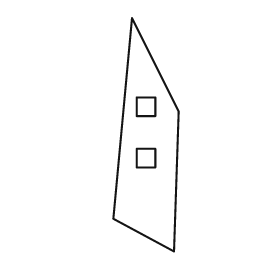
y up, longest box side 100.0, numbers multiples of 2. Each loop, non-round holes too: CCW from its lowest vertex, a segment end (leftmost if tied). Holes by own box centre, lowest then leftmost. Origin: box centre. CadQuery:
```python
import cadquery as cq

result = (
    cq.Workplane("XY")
    .moveTo(12.0, -50.0)
    .lineTo(14.0, 10.0)
    .lineTo(-6.0, 50.0)
    .lineTo(-14.0, -36.0)
    .close()
    .moveTo(-4.0, -14.0)
    .lineTo(4.0, -14.0)
    .lineTo(4.0, -6.0)
    .lineTo(-4.0, -6.0)
    .close()
    .moveTo(-4.0, 8.0)
    .lineTo(4.0, 8.0)
    .lineTo(4.0, 16.0)
    .lineTo(-4.0, 16.0)
    .close()
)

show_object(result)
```